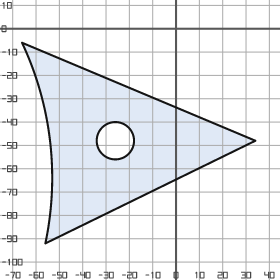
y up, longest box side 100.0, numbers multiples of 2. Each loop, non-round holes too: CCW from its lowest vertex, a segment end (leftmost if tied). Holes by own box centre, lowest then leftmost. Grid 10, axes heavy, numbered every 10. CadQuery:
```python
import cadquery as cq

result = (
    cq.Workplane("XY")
    .moveTo(-56.0, -92.0)
    .lineTo(34.0, -48.0)
    .lineTo(-66.0, -6.0)
    .threePointArc((-54.0, -48.0), (-56.0, -92.0))
    .close()
    .moveTo(-26.0, -48.0)
    .circle(8.0)
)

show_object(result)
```